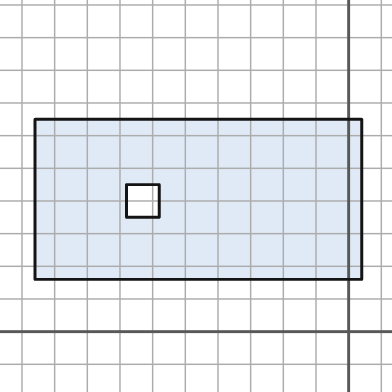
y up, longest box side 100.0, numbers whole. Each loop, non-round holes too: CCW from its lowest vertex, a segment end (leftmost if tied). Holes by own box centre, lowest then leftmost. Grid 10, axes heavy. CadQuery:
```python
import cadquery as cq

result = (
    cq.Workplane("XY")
    .moveTo(-96.0, 16.0)
    .lineTo(4.0, 16.0)
    .lineTo(4.0, 65.0)
    .lineTo(-96.0, 65.0)
    .close()
    .moveTo(-68.0, 35.0)
    .lineTo(-58.0, 35.0)
    .lineTo(-58.0, 45.0)
    .lineTo(-68.0, 45.0)
    .close()
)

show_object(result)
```